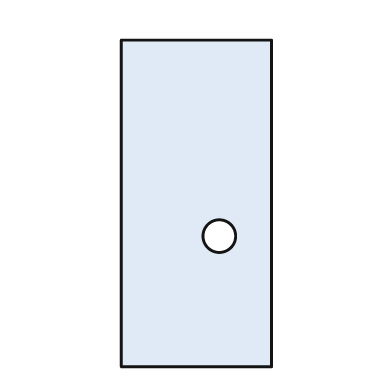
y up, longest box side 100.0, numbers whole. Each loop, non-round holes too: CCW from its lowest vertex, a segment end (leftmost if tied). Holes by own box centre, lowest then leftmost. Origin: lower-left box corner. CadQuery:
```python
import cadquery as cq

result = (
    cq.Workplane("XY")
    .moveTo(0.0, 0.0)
    .lineTo(46.0, 0.0)
    .lineTo(46.0, 100.0)
    .lineTo(0.0, 100.0)
    .close()
    .moveTo(30.0, 40.0)
    .circle(5.0)
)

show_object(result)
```